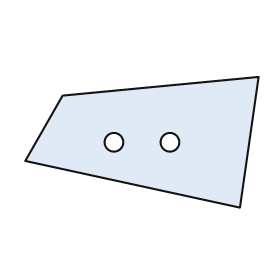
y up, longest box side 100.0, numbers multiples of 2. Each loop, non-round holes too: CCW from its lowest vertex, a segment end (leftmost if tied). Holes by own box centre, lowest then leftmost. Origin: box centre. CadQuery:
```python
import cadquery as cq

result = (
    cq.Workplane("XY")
    .moveTo(42.0, -28.0)
    .lineTo(50.0, 28.0)
    .lineTo(-34.0, 20.0)
    .lineTo(-50.0, -8.0)
    .close()
    .moveTo(-12.0, 0.0)
    .circle(4.0)
    .moveTo(12.0, 0.0)
    .circle(4.0)
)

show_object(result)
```